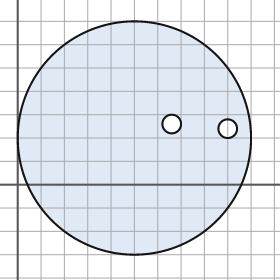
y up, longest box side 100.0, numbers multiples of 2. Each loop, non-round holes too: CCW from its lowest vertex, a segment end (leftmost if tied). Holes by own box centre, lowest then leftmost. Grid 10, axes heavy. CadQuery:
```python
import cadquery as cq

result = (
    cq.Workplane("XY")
    .moveTo(50.0, 20.0)
    .circle(50.0)
    .moveTo(90.0, 24.0)
    .circle(4.0)
    .moveTo(66.0, 26.0)
    .circle(4.0)
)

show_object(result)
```